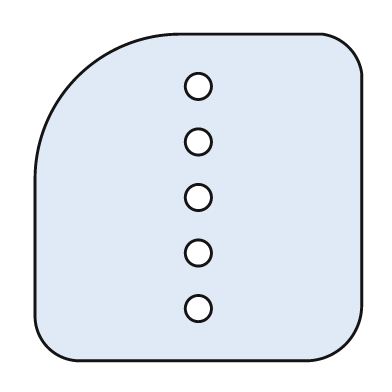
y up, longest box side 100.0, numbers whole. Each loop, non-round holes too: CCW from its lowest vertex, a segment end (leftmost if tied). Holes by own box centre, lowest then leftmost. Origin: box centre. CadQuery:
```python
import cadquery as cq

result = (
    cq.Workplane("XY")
    .moveTo(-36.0, -50.0)
    .lineTo(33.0, -50.0)
    .threePointArc((45.0, -45.0), (50.0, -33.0))
    .lineTo(50.0, 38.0)
    .threePointArc((46.0, 46.0), (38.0, 50.0))
    .lineTo(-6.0, 50.0)
    .threePointArc((-37.0, 37.0), (-50.0, 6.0))
    .lineTo(-50.0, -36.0)
    .threePointArc((-46.0, -46.0), (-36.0, -50.0))
    .close()
    .moveTo(0.0, -34.0)
    .circle(4.0)
    .moveTo(0.0, -17.0)
    .circle(4.0)
    .moveTo(0.0, 0.0)
    .circle(4.0)
    .moveTo(0.0, 17.0)
    .circle(4.0)
    .moveTo(0.0, 34.0)
    .circle(4.0)
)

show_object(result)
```